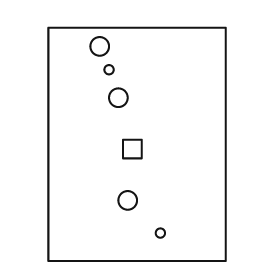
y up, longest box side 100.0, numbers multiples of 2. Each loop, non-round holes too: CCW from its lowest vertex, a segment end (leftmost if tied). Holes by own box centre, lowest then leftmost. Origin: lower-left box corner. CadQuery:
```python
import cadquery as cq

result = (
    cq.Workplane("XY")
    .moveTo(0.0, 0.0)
    .lineTo(76.0, 0.0)
    .lineTo(76.0, 100.0)
    .lineTo(0.0, 100.0)
    .close()
    .moveTo(48.0, 12.0)
    .circle(2.0)
    .moveTo(34.0, 26.0)
    .circle(4.0)
    .moveTo(32.0, 44.0)
    .lineTo(40.0, 44.0)
    .lineTo(40.0, 52.0)
    .lineTo(32.0, 52.0)
    .close()
    .moveTo(30.0, 70.0)
    .circle(4.0)
    .moveTo(26.0, 82.0)
    .circle(2.0)
    .moveTo(22.0, 92.0)
    .circle(4.0)
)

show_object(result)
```